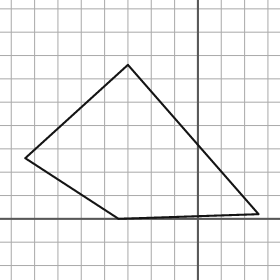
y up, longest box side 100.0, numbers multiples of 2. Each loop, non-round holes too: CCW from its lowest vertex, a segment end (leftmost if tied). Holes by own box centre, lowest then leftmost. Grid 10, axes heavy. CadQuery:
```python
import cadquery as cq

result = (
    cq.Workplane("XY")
    .moveTo(-34.0, 0.0)
    .lineTo(26.0, 2.0)
    .lineTo(-30.0, 66.0)
    .lineTo(-74.0, 26.0)
    .close()
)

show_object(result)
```